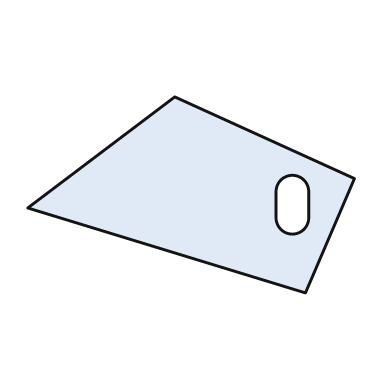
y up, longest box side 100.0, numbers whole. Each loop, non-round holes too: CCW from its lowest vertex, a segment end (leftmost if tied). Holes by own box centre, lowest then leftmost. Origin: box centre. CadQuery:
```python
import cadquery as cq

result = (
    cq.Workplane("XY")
    .moveTo(35.0, -30.0)
    .lineTo(50.0, 5.0)
    .lineTo(-5.0, 30.0)
    .lineTo(-50.0, -4.0)
    .close()
    .moveTo(26.0, -7.0)
    .threePointArc((31.0, -12.0), (36.0, -7.0))
    .lineTo(36.0, 1.0)
    .threePointArc((31.0, 6.0), (26.0, 1.0))
    .close()
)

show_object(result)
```